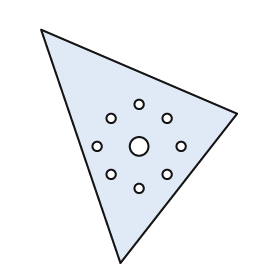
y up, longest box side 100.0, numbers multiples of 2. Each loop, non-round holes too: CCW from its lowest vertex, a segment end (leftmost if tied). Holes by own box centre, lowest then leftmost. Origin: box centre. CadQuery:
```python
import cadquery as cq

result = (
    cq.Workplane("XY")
    .moveTo(-8.0, -50.0)
    .lineTo(42.0, 14.0)
    .lineTo(-42.0, 50.0)
    .close()
    .moveTo(0.0, -18.0)
    .circle(2.0)
    .moveTo(-12.0, -12.0)
    .circle(2.0)
    .moveTo(12.0, -12.0)
    .circle(2.0)
    .moveTo(-18.0, 0.0)
    .circle(2.0)
    .moveTo(0.0, 0.0)
    .circle(4.0)
    .moveTo(18.0, 0.0)
    .circle(2.0)
    .moveTo(-12.0, 12.0)
    .circle(2.0)
    .moveTo(12.0, 12.0)
    .circle(2.0)
    .moveTo(0.0, 18.0)
    .circle(2.0)
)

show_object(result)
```